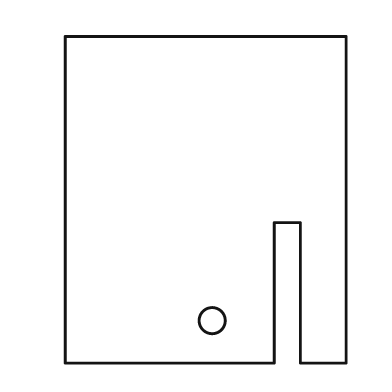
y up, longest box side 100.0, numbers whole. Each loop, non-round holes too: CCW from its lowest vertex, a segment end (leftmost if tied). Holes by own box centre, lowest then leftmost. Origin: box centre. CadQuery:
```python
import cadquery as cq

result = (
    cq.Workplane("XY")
    .moveTo(-43.0, -50.0)
    .lineTo(21.0, -50.0)
    .lineTo(21.0, -7.0)
    .lineTo(29.0, -7.0)
    .lineTo(29.0, -50.0)
    .lineTo(43.0, -50.0)
    .lineTo(43.0, 50.0)
    .lineTo(-43.0, 50.0)
    .close()
    .moveTo(2.0, -37.0)
    .circle(4.0)
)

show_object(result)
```